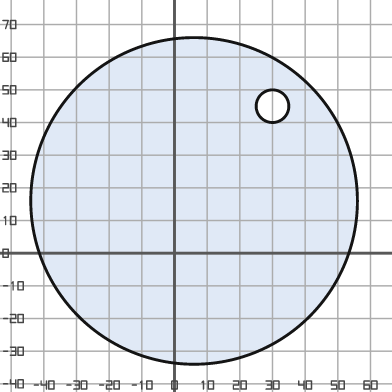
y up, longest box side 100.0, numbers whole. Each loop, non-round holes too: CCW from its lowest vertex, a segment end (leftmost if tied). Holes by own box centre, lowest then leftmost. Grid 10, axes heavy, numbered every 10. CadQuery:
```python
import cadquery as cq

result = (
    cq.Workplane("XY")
    .moveTo(6.0, 16.0)
    .circle(50.0)
    .moveTo(30.0, 45.0)
    .circle(5.0)
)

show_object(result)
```